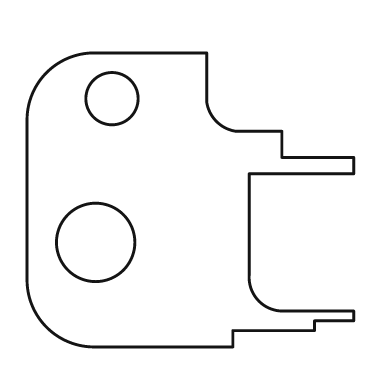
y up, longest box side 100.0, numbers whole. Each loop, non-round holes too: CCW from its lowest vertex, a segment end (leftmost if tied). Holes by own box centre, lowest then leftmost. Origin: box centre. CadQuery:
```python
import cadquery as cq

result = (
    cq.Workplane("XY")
    .moveTo(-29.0, -45.0)
    .lineTo(13.0, -45.0)
    .lineTo(13.0, -40.0)
    .lineTo(38.0, -40.0)
    .lineTo(38.0, -37.0)
    .lineTo(50.0, -37.0)
    .lineTo(50.0, -34.0)
    .lineTo(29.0, -34.0)
    .threePointArc((21.0, -31.0), (18.0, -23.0))
    .lineTo(18.0, 8.0)
    .lineTo(50.0, 8.0)
    .lineTo(50.0, 13.0)
    .lineTo(28.0, 13.0)
    .lineTo(28.0, 21.0)
    .lineTo(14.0, 21.0)
    .threePointArc((8.0, 24.0), (5.0, 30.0))
    .lineTo(5.0, 45.0)
    .lineTo(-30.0, 45.0)
    .threePointArc((-44.0, 39.0), (-50.0, 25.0))
    .lineTo(-50.0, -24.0)
    .threePointArc((-44.0, -39.0), (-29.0, -45.0))
    .close()
    .moveTo(-29.0, -13.0)
    .circle(12.0)
    .moveTo(-24.0, 31.0)
    .circle(8.0)
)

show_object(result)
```